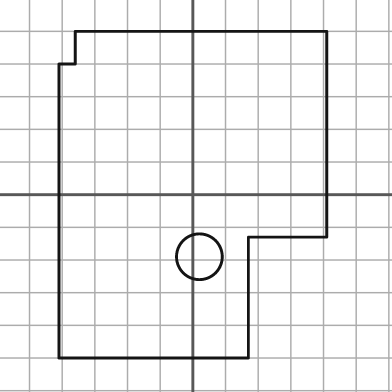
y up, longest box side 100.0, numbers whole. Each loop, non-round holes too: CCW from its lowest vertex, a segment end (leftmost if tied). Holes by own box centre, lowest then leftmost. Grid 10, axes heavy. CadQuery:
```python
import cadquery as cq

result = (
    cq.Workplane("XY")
    .moveTo(-41.0, -50.0)
    .lineTo(17.0, -50.0)
    .lineTo(17.0, -13.0)
    .lineTo(41.0, -13.0)
    .lineTo(41.0, 50.0)
    .lineTo(-36.0, 50.0)
    .lineTo(-36.0, 40.0)
    .lineTo(-41.0, 40.0)
    .close()
    .moveTo(2.0, -19.0)
    .circle(7.0)
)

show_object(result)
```